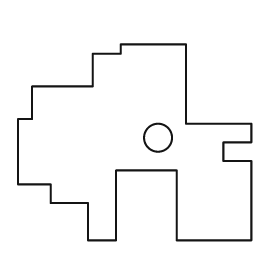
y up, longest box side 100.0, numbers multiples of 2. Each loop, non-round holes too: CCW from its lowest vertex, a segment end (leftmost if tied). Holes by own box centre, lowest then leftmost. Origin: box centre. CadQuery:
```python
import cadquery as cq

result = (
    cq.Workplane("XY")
    .moveTo(-20.0, -42.0)
    .lineTo(-8.0, -42.0)
    .lineTo(-8.0, -12.0)
    .lineTo(18.0, -12.0)
    .lineTo(18.0, -42.0)
    .lineTo(50.0, -42.0)
    .lineTo(50.0, -8.0)
    .lineTo(38.0, -8.0)
    .lineTo(38.0, 0.0)
    .lineTo(50.0, 0.0)
    .lineTo(50.0, 8.0)
    .lineTo(22.0, 8.0)
    .lineTo(22.0, 42.0)
    .lineTo(-6.0, 42.0)
    .lineTo(-6.0, 38.0)
    .lineTo(-18.0, 38.0)
    .lineTo(-18.0, 24.0)
    .lineTo(-44.0, 24.0)
    .lineTo(-44.0, 10.0)
    .lineTo(-50.0, 10.0)
    .lineTo(-50.0, -18.0)
    .lineTo(-36.0, -18.0)
    .lineTo(-36.0, -26.0)
    .lineTo(-20.0, -26.0)
    .close()
    .moveTo(10.0, 2.0)
    .circle(6.0)
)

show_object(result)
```